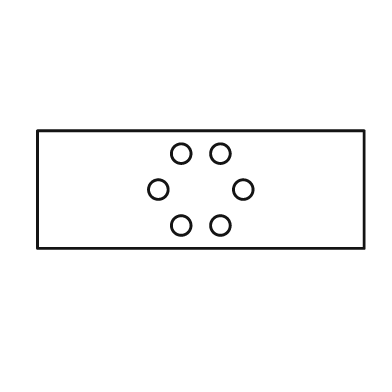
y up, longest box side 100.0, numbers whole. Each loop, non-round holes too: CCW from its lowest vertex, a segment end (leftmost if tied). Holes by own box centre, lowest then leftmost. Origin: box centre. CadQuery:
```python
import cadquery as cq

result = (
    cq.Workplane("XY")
    .moveTo(-50.0, -18.0)
    .lineTo(50.0, -18.0)
    .lineTo(50.0, 18.0)
    .lineTo(-50.0, 18.0)
    .close()
    .moveTo(-6.0, -11.0)
    .circle(3.0)
    .moveTo(6.0, -11.0)
    .circle(3.0)
    .moveTo(-13.0, 0.0)
    .circle(3.0)
    .moveTo(13.0, 0.0)
    .circle(3.0)
    .moveTo(-6.0, 11.0)
    .circle(3.0)
    .moveTo(6.0, 11.0)
    .circle(3.0)
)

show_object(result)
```